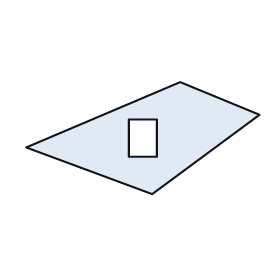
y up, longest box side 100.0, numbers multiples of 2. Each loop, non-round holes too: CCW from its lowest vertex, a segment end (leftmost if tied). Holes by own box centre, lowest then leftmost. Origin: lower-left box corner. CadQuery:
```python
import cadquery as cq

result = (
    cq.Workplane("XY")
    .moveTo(54.0, 0.0)
    .lineTo(100.0, 34.0)
    .lineTo(66.0, 48.0)
    .lineTo(0.0, 20.0)
    .close()
    .moveTo(44.0, 16.0)
    .lineTo(56.0, 16.0)
    .lineTo(56.0, 32.0)
    .lineTo(44.0, 32.0)
    .close()
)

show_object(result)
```